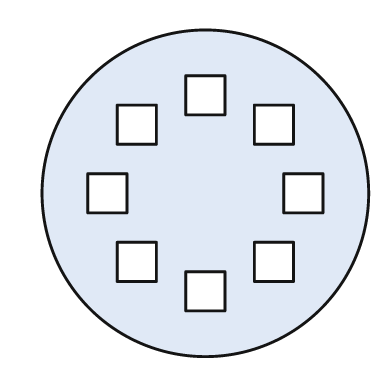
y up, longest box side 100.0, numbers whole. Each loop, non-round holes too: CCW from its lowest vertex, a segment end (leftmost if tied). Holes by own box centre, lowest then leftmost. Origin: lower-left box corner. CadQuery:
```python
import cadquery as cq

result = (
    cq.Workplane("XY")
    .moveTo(50.0, 50.0)
    .circle(50.0)
    .moveTo(44.0, 14.0)
    .lineTo(56.0, 14.0)
    .lineTo(56.0, 26.0)
    .lineTo(44.0, 26.0)
    .close()
    .moveTo(23.0, 23.0)
    .lineTo(35.0, 23.0)
    .lineTo(35.0, 35.0)
    .lineTo(23.0, 35.0)
    .close()
    .moveTo(65.0, 23.0)
    .lineTo(77.0, 23.0)
    .lineTo(77.0, 35.0)
    .lineTo(65.0, 35.0)
    .close()
    .moveTo(14.0, 44.0)
    .lineTo(26.0, 44.0)
    .lineTo(26.0, 56.0)
    .lineTo(14.0, 56.0)
    .close()
    .moveTo(74.0, 44.0)
    .lineTo(86.0, 44.0)
    .lineTo(86.0, 56.0)
    .lineTo(74.0, 56.0)
    .close()
    .moveTo(23.0, 65.0)
    .lineTo(35.0, 65.0)
    .lineTo(35.0, 77.0)
    .lineTo(23.0, 77.0)
    .close()
    .moveTo(65.0, 65.0)
    .lineTo(77.0, 65.0)
    .lineTo(77.0, 77.0)
    .lineTo(65.0, 77.0)
    .close()
    .moveTo(44.0, 74.0)
    .lineTo(56.0, 74.0)
    .lineTo(56.0, 86.0)
    .lineTo(44.0, 86.0)
    .close()
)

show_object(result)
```